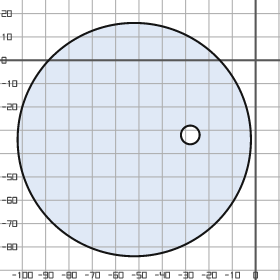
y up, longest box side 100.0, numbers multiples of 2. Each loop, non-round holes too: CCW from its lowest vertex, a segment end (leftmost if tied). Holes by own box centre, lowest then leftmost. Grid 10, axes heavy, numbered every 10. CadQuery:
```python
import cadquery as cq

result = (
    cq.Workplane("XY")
    .moveTo(-52.0, -34.0)
    .circle(50.0)
    .moveTo(-28.0, -32.0)
    .circle(4.0)
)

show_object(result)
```